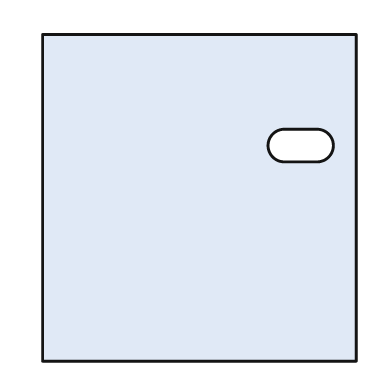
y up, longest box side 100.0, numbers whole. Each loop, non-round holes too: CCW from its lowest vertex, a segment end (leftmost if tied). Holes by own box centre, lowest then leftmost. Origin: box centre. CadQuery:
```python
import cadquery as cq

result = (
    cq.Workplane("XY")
    .moveTo(-48.0, -50.0)
    .lineTo(48.0, -50.0)
    .lineTo(48.0, 50.0)
    .lineTo(-48.0, 50.0)
    .close()
    .moveTo(26.0, 11.0)
    .lineTo(36.0, 11.0)
    .threePointArc((41.0, 16.0), (36.0, 21.0))
    .lineTo(26.0, 21.0)
    .threePointArc((21.0, 16.0), (26.0, 11.0))
    .close()
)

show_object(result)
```